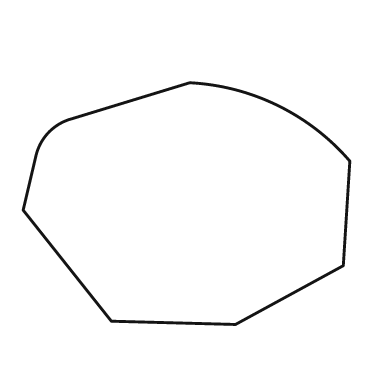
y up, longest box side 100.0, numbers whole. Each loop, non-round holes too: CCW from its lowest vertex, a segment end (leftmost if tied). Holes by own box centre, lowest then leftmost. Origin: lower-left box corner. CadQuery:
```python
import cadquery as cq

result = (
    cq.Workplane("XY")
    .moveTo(65.0, 0.0)
    .lineTo(98.0, 18.0)
    .lineTo(100.0, 50.0)
    .threePointArc((78.0, 67.0), (51.0, 74.0))
    .lineTo(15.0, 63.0)
    .threePointArc((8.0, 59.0), (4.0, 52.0))
    .lineTo(0.0, 35.0)
    .lineTo(27.0, 1.0)
    .close()
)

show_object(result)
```